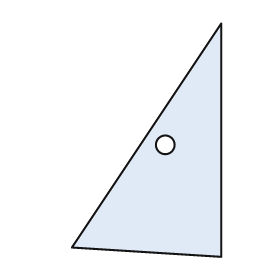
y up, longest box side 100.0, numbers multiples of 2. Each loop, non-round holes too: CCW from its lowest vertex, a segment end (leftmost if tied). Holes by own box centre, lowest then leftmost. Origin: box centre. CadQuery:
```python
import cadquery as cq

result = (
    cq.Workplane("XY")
    .moveTo(32.0, -50.0)
    .lineTo(32.0, 50.0)
    .lineTo(-32.0, -46.0)
    .close()
    .moveTo(8.0, -2.0)
    .circle(4.0)
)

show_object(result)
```